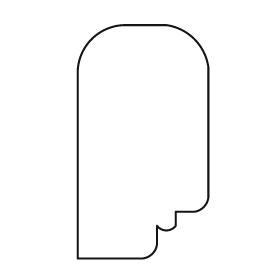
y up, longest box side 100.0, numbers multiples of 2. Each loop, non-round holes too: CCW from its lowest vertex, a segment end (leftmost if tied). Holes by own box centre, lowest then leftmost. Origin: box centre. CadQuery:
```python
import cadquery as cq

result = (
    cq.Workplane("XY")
    .moveTo(-28.0, -50.0)
    .lineTo(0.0, -50.0)
    .threePointArc((4.0, -48.0), (6.0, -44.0))
    .lineTo(6.0, -36.0)
    .threePointArc((10.0, -38.0), (14.0, -36.0))
    .lineTo(14.0, -30.0)
    .lineTo(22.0, -30.0)
    .threePointArc((26.0, -28.0), (28.0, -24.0))
    .lineTo(28.0, 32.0)
    .threePointArc((22.0, 44.0), (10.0, 50.0))
    .lineTo(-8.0, 50.0)
    .threePointArc((-22.0, 44.0), (-28.0, 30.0))
    .close()
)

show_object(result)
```